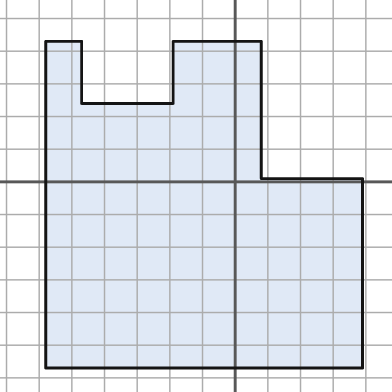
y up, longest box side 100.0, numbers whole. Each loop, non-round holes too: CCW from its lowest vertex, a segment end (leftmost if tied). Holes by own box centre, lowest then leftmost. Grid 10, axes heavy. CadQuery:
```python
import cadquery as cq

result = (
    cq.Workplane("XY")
    .moveTo(-58.0, -57.0)
    .lineTo(39.0, -57.0)
    .lineTo(39.0, 1.0)
    .lineTo(8.0, 1.0)
    .lineTo(8.0, 43.0)
    .lineTo(-19.0, 43.0)
    .lineTo(-19.0, 24.0)
    .lineTo(-47.0, 24.0)
    .lineTo(-47.0, 43.0)
    .lineTo(-58.0, 43.0)
    .close()
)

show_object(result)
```